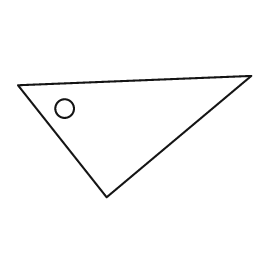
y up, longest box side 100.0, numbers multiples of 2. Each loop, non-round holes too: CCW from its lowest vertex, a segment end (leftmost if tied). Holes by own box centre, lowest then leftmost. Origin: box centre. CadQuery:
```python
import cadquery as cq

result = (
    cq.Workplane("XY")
    .moveTo(-12.0, -26.0)
    .lineTo(50.0, 26.0)
    .lineTo(-50.0, 22.0)
    .close()
    .moveTo(-30.0, 12.0)
    .circle(4.0)
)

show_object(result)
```